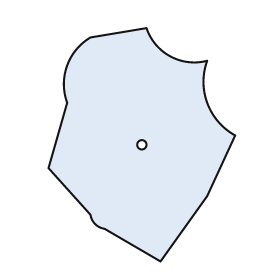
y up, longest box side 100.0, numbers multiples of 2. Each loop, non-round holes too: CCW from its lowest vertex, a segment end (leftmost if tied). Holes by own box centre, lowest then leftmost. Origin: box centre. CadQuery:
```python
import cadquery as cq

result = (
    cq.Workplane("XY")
    .moveTo(8.0, -50.0)
    .lineTo(28.0, -22.0)
    .lineTo(40.0, 4.0)
    .threePointArc((28.0, 18.0), (28.0, 36.0))
    .threePointArc((12.0, 38.0), (2.0, 50.0))
    .lineTo(-22.0, 46.0)
    .threePointArc((-32.0, 34.0), (-32.0, 18.0))
    .lineTo(-40.0, -10.0)
    .lineTo(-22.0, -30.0)
    .threePointArc((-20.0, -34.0), (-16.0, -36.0))
    .close()
    .moveTo(0.0, 0.0)
    .circle(2.0)
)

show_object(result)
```